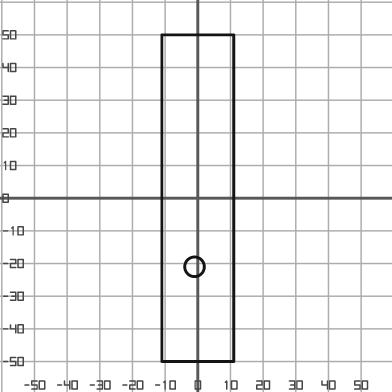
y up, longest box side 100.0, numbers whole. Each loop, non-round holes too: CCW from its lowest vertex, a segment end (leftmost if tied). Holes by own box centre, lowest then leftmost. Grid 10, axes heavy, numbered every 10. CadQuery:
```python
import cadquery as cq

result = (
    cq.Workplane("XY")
    .moveTo(-11.0, -50.0)
    .lineTo(11.0, -50.0)
    .lineTo(11.0, 50.0)
    .lineTo(-11.0, 50.0)
    .close()
    .moveTo(-1.0, -21.0)
    .circle(3.0)
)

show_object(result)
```